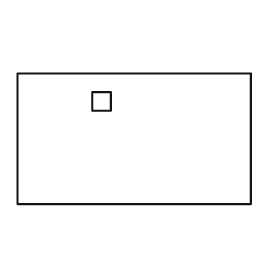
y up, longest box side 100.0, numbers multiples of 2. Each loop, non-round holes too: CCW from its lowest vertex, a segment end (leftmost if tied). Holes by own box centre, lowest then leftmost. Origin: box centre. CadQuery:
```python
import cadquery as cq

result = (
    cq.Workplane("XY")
    .moveTo(-50.0, -28.0)
    .lineTo(50.0, -28.0)
    .lineTo(50.0, 28.0)
    .lineTo(-50.0, 28.0)
    .close()
    .moveTo(-18.0, 12.0)
    .lineTo(-10.0, 12.0)
    .lineTo(-10.0, 20.0)
    .lineTo(-18.0, 20.0)
    .close()
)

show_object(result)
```